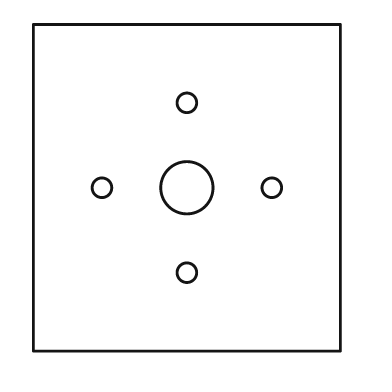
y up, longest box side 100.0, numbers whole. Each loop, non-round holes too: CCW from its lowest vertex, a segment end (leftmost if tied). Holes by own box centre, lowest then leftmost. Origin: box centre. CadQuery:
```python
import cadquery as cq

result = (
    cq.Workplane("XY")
    .moveTo(-47.0, -50.0)
    .lineTo(47.0, -50.0)
    .lineTo(47.0, 50.0)
    .lineTo(-47.0, 50.0)
    .close()
    .moveTo(0.0, -26.0)
    .circle(3.0)
    .moveTo(-26.0, 0.0)
    .circle(3.0)
    .moveTo(0.0, 0.0)
    .circle(8.0)
    .moveTo(26.0, 0.0)
    .circle(3.0)
    .moveTo(0.0, 26.0)
    .circle(3.0)
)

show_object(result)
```